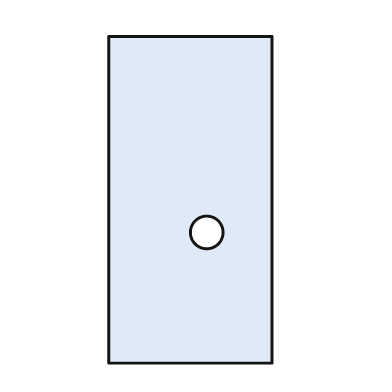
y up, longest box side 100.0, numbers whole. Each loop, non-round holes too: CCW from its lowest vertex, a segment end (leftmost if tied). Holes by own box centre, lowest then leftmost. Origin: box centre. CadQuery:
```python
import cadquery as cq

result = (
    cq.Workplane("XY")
    .moveTo(-25.0, -50.0)
    .lineTo(25.0, -50.0)
    .lineTo(25.0, 50.0)
    .lineTo(-25.0, 50.0)
    .close()
    .moveTo(5.0, -10.0)
    .circle(5.0)
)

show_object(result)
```